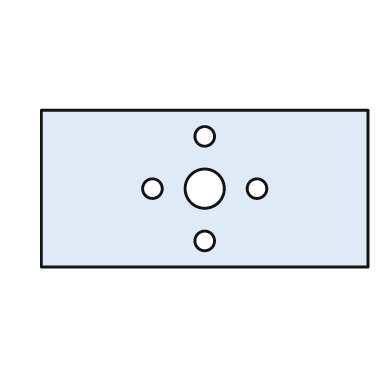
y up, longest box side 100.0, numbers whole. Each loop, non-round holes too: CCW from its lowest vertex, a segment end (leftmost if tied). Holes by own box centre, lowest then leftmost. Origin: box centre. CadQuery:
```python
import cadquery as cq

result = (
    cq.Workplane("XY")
    .moveTo(-50.0, -24.0)
    .lineTo(50.0, -24.0)
    .lineTo(50.0, 24.0)
    .lineTo(-50.0, 24.0)
    .close()
    .moveTo(0.0, -16.0)
    .circle(3.0)
    .moveTo(-16.0, 0.0)
    .circle(3.0)
    .moveTo(0.0, 0.0)
    .circle(6.0)
    .moveTo(16.0, 0.0)
    .circle(3.0)
    .moveTo(0.0, 16.0)
    .circle(3.0)
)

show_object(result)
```